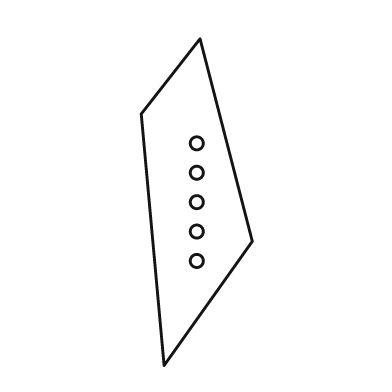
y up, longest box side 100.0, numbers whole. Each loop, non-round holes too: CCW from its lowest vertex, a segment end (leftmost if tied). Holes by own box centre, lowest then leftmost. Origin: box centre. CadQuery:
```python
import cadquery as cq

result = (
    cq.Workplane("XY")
    .moveTo(-10.0, -50.0)
    .lineTo(17.0, -12.0)
    .lineTo(1.0, 50.0)
    .lineTo(-17.0, 27.0)
    .close()
    .moveTo(0.0, -18.0)
    .circle(2.0)
    .moveTo(0.0, -9.0)
    .circle(2.0)
    .moveTo(0.0, 0.0)
    .circle(2.0)
    .moveTo(0.0, 9.0)
    .circle(2.0)
    .moveTo(0.0, 18.0)
    .circle(2.0)
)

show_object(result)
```